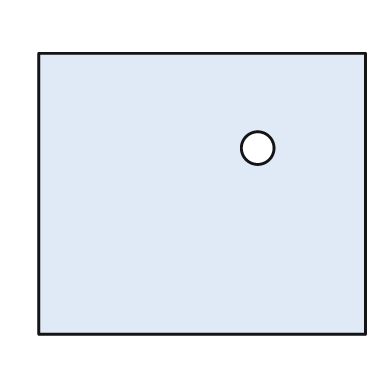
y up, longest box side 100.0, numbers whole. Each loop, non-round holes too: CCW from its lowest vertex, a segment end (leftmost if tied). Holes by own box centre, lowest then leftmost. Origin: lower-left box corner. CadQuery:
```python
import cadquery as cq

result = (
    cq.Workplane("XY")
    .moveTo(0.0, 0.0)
    .lineTo(100.0, 0.0)
    .lineTo(100.0, 86.0)
    .lineTo(0.0, 86.0)
    .close()
    .moveTo(67.0, 57.0)
    .circle(5.0)
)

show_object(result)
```